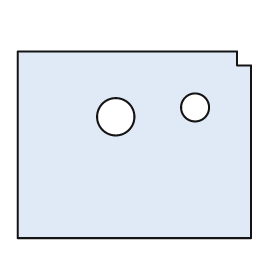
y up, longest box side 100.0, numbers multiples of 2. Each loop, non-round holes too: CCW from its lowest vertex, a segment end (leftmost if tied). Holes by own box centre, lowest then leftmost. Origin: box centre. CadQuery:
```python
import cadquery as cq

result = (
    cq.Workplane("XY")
    .moveTo(-50.0, -40.0)
    .lineTo(50.0, -40.0)
    .lineTo(50.0, 34.0)
    .lineTo(44.0, 34.0)
    .lineTo(44.0, 40.0)
    .lineTo(-50.0, 40.0)
    .close()
    .moveTo(-8.0, 12.0)
    .circle(8.0)
    .moveTo(26.0, 16.0)
    .circle(6.0)
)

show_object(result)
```